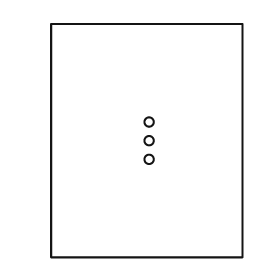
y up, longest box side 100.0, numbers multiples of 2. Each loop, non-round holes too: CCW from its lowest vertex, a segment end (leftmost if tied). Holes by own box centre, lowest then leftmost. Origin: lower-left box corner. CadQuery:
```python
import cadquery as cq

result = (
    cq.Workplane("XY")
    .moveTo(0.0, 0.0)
    .lineTo(82.0, 0.0)
    .lineTo(82.0, 100.0)
    .lineTo(0.0, 100.0)
    .close()
    .moveTo(42.0, 42.0)
    .circle(2.0)
    .moveTo(42.0, 50.0)
    .circle(2.0)
    .moveTo(42.0, 58.0)
    .circle(2.0)
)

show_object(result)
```